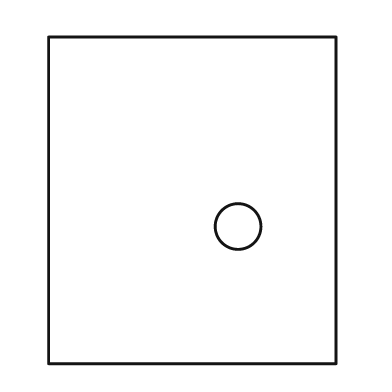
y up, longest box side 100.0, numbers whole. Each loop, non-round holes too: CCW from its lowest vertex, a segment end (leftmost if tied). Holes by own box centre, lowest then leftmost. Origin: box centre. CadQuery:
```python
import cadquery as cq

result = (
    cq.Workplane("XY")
    .moveTo(-44.0, -50.0)
    .lineTo(44.0, -50.0)
    .lineTo(44.0, 50.0)
    .lineTo(-44.0, 50.0)
    .close()
    .moveTo(14.0, -8.0)
    .circle(7.0)
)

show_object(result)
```